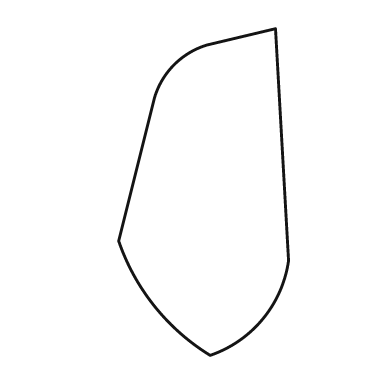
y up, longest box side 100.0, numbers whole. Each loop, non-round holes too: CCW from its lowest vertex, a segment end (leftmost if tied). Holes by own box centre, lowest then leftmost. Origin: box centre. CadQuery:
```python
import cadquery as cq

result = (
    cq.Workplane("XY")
    .moveTo(2.0, -50.0)
    .threePointArc((18.0, -39.0), (26.0, -21.0))
    .lineTo(22.0, 50.0)
    .lineTo(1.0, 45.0)
    .threePointArc((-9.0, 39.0), (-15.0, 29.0))
    .lineTo(-26.0, -15.0)
    .threePointArc((-15.0, -35.0), (2.0, -50.0))
    .close()
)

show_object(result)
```